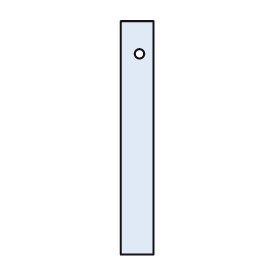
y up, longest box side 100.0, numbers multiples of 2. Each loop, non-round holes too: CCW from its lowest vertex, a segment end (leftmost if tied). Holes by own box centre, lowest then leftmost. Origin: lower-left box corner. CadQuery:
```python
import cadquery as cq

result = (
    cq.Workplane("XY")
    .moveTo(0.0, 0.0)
    .lineTo(14.0, 0.0)
    .lineTo(14.0, 100.0)
    .lineTo(0.0, 100.0)
    .close()
    .moveTo(8.0, 86.0)
    .circle(2.0)
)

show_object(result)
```